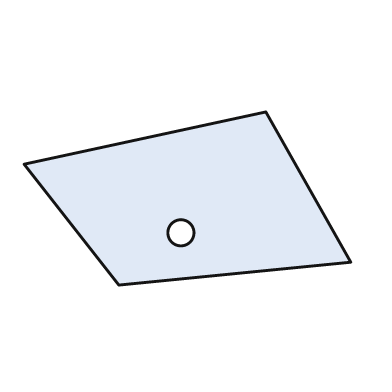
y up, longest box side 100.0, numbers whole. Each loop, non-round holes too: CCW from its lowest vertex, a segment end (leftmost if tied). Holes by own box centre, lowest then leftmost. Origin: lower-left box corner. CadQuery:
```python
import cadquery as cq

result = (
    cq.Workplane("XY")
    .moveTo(29.0, 0.0)
    .lineTo(100.0, 7.0)
    .lineTo(74.0, 53.0)
    .lineTo(0.0, 37.0)
    .close()
    .moveTo(48.0, 16.0)
    .circle(4.0)
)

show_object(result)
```